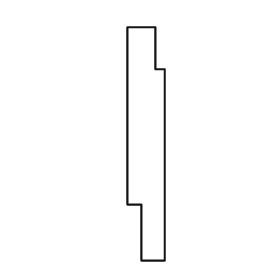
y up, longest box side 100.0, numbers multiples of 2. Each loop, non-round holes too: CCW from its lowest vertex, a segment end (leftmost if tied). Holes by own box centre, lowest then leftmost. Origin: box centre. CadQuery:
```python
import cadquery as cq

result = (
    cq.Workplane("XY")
    .moveTo(-2.0, -50.0)
    .lineTo(8.0, -50.0)
    .lineTo(8.0, 32.0)
    .lineTo(4.0, 32.0)
    .lineTo(4.0, 50.0)
    .lineTo(-8.0, 50.0)
    .lineTo(-8.0, -26.0)
    .lineTo(-2.0, -26.0)
    .close()
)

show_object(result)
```